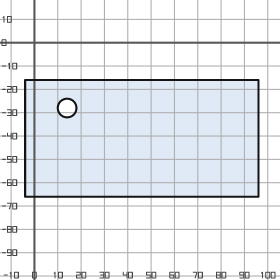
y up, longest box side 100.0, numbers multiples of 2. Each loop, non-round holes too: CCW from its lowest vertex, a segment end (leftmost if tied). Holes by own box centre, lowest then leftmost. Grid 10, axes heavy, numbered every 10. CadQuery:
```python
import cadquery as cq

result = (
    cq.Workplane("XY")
    .moveTo(-4.0, -66.0)
    .lineTo(96.0, -66.0)
    .lineTo(96.0, -16.0)
    .lineTo(-4.0, -16.0)
    .close()
    .moveTo(14.0, -28.0)
    .circle(4.0)
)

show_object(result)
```